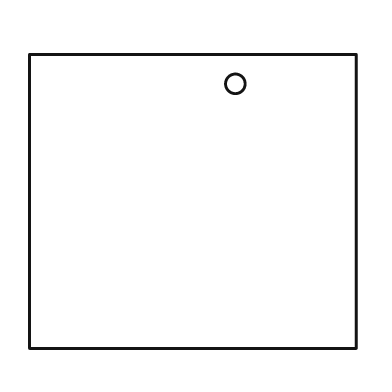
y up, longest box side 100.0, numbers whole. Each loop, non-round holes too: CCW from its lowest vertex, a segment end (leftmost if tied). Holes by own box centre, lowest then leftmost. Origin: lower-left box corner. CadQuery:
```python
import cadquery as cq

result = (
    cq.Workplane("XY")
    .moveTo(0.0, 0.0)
    .lineTo(100.0, 0.0)
    .lineTo(100.0, 90.0)
    .lineTo(0.0, 90.0)
    .close()
    .moveTo(63.0, 81.0)
    .circle(3.0)
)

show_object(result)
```